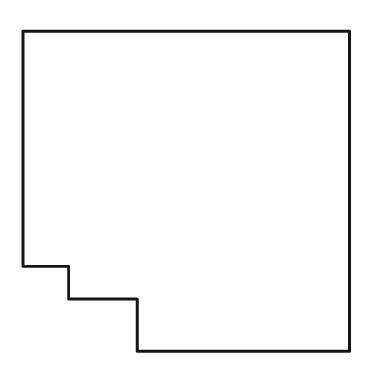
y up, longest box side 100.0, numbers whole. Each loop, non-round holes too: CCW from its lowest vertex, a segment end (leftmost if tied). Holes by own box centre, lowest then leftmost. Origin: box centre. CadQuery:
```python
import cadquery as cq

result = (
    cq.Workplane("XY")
    .moveTo(-15.0, -49.0)
    .lineTo(50.0, -49.0)
    .lineTo(50.0, 49.0)
    .lineTo(-50.0, 49.0)
    .lineTo(-50.0, -23.0)
    .lineTo(-36.0, -23.0)
    .lineTo(-36.0, -33.0)
    .lineTo(-15.0, -33.0)
    .close()
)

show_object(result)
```